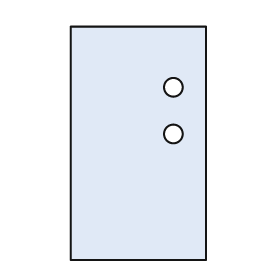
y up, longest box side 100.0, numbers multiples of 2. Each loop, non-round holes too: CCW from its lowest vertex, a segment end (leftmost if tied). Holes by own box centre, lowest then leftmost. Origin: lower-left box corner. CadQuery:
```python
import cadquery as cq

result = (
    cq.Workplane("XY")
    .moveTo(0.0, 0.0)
    .lineTo(58.0, 0.0)
    .lineTo(58.0, 100.0)
    .lineTo(0.0, 100.0)
    .close()
    .moveTo(44.0, 54.0)
    .circle(4.0)
    .moveTo(44.0, 74.0)
    .circle(4.0)
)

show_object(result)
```